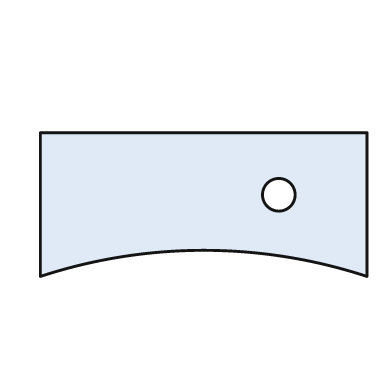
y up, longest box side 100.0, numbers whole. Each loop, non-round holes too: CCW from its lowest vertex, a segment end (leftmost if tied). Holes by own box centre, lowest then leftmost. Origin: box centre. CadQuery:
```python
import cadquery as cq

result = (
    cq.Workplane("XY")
    .moveTo(-50.0, -22.0)
    .threePointArc((0.0, -14.0), (50.0, -22.0))
    .lineTo(50.0, 22.0)
    .lineTo(-50.0, 22.0)
    .close()
    .moveTo(23.0, 3.0)
    .circle(5.0)
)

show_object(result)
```